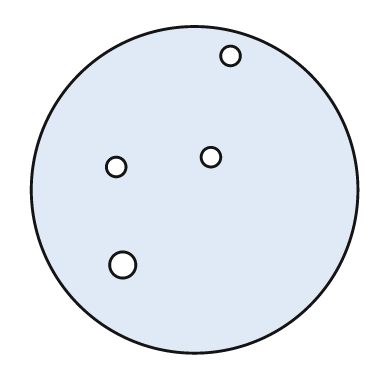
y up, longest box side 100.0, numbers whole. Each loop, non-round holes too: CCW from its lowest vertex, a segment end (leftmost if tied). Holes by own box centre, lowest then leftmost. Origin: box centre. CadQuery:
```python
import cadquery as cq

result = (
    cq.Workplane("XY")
    .moveTo(0.0, 0.0)
    .circle(50.0)
    .moveTo(-22.0, -23.0)
    .circle(4.0)
    .moveTo(-24.0, 7.0)
    .circle(3.0)
    .moveTo(5.0, 10.0)
    .circle(3.0)
    .moveTo(11.0, 41.0)
    .circle(3.0)
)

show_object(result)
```